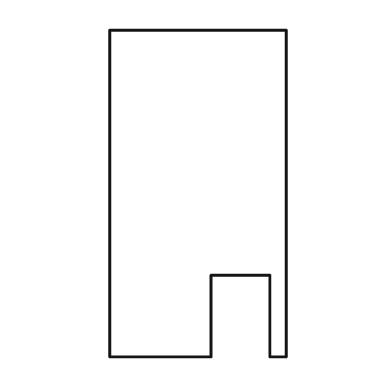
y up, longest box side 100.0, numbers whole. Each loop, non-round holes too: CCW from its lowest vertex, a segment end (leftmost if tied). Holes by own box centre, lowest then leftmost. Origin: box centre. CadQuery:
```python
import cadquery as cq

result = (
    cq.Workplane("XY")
    .moveTo(-27.0, -50.0)
    .lineTo(4.0, -50.0)
    .lineTo(4.0, -25.0)
    .lineTo(22.0, -25.0)
    .lineTo(22.0, -50.0)
    .lineTo(27.0, -50.0)
    .lineTo(27.0, 50.0)
    .lineTo(-27.0, 50.0)
    .close()
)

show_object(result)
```